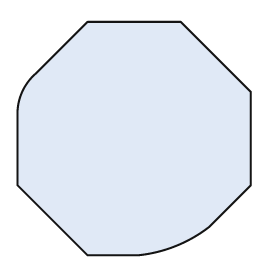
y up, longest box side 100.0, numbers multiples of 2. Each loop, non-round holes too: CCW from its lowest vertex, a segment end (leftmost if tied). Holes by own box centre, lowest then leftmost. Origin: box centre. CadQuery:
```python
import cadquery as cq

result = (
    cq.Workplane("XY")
    .moveTo(-20.0, -50.0)
    .lineTo(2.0, -50.0)
    .threePointArc((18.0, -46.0), (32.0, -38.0))
    .lineTo(50.0, -20.0)
    .lineTo(50.0, 20.0)
    .lineTo(20.0, 50.0)
    .lineTo(-20.0, 50.0)
    .lineTo(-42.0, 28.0)
    .threePointArc((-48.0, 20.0), (-50.0, 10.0))
    .lineTo(-50.0, -20.0)
    .close()
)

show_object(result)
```